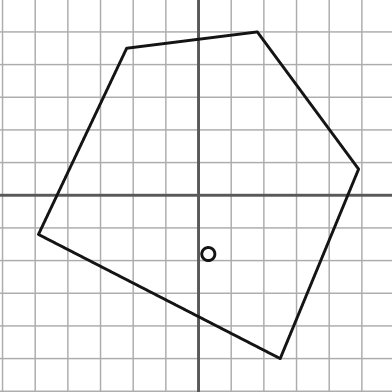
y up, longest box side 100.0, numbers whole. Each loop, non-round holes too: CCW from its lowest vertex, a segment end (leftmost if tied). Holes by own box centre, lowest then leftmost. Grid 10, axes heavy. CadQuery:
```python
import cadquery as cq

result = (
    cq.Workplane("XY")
    .moveTo(25.0, -50.0)
    .lineTo(49.0, 8.0)
    .lineTo(18.0, 50.0)
    .lineTo(-22.0, 45.0)
    .lineTo(-49.0, -12.0)
    .close()
    .moveTo(3.0, -18.0)
    .circle(2.0)
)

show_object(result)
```